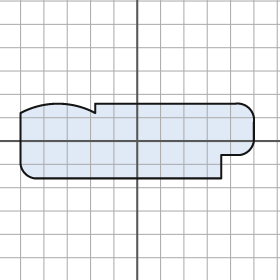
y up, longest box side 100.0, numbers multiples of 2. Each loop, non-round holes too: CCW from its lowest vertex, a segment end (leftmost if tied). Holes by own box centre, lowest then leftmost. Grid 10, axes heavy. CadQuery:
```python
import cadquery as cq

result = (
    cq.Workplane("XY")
    .moveTo(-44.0, -16.0)
    .lineTo(36.0, -16.0)
    .lineTo(36.0, -6.0)
    .lineTo(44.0, -6.0)
    .threePointArc((48.0, -4.0), (50.0, 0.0))
    .lineTo(50.0, 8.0)
    .threePointArc((48.0, 14.0), (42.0, 16.0))
    .lineTo(-18.0, 16.0)
    .lineTo(-18.0, 12.0)
    .threePointArc((-34.0, 16.0), (-50.0, 12.0))
    .lineTo(-50.0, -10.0)
    .threePointArc((-48.0, -14.0), (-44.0, -16.0))
    .close()
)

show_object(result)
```